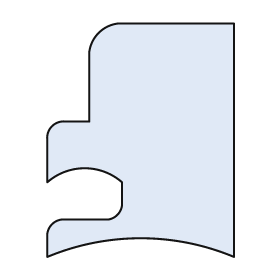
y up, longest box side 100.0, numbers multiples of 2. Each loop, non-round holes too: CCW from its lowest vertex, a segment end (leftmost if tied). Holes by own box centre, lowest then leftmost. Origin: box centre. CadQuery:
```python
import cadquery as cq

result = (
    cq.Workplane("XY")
    .moveTo(-40.0, -50.0)
    .threePointArc((0.0, -42.0), (40.0, -50.0))
    .lineTo(40.0, 50.0)
    .lineTo(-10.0, 50.0)
    .threePointArc((-18.0, 46.0), (-22.0, 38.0))
    .lineTo(-22.0, 8.0)
    .lineTo(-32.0, 8.0)
    .threePointArc((-38.0, 6.0), (-40.0, 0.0))
    .lineTo(-40.0, -18.0)
    .threePointArc((-24.0, -12.0), (-8.0, -18.0))
    .lineTo(-8.0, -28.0)
    .threePointArc((-10.0, -32.0), (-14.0, -34.0))
    .lineTo(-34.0, -34.0)
    .threePointArc((-38.0, -36.0), (-40.0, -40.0))
    .close()
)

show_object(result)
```